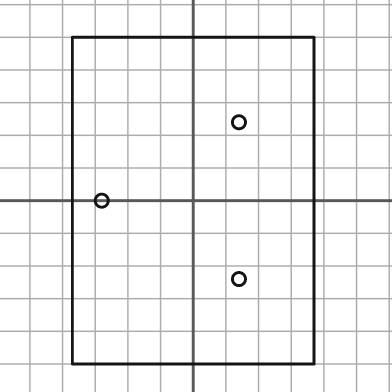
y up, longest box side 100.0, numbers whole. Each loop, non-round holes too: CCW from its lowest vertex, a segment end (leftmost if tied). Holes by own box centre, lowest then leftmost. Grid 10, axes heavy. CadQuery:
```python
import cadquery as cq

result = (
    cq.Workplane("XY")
    .moveTo(-37.0, -50.0)
    .lineTo(37.0, -50.0)
    .lineTo(37.0, 50.0)
    .lineTo(-37.0, 50.0)
    .close()
    .moveTo(14.0, -24.0)
    .circle(2.0)
    .moveTo(-28.0, 0.0)
    .circle(2.0)
    .moveTo(14.0, 24.0)
    .circle(2.0)
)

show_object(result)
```